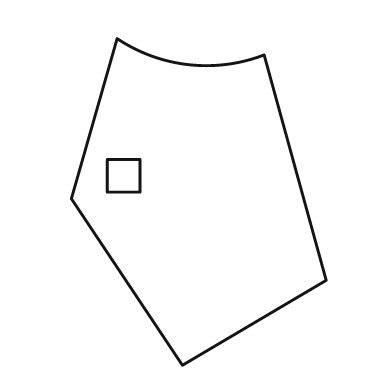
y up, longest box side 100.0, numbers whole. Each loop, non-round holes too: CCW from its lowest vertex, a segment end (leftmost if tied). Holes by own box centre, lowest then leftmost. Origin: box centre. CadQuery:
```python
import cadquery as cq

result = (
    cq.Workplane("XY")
    .moveTo(-5.0, -50.0)
    .lineTo(39.0, -24.0)
    .lineTo(20.0, 45.0)
    .threePointArc((-3.0, 42.0), (-25.0, 50.0))
    .lineTo(-39.0, 1.0)
    .close()
    .moveTo(-28.0, 3.0)
    .lineTo(-18.0, 3.0)
    .lineTo(-18.0, 13.0)
    .lineTo(-28.0, 13.0)
    .close()
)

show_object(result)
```